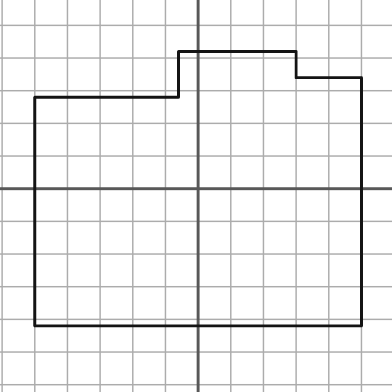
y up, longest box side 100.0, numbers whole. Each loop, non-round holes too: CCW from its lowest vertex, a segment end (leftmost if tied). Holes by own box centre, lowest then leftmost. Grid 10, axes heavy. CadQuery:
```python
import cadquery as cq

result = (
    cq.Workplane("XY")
    .moveTo(-50.0, -42.0)
    .lineTo(50.0, -42.0)
    .lineTo(50.0, 34.0)
    .lineTo(30.0, 34.0)
    .lineTo(30.0, 42.0)
    .lineTo(-6.0, 42.0)
    .lineTo(-6.0, 28.0)
    .lineTo(-50.0, 28.0)
    .close()
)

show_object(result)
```